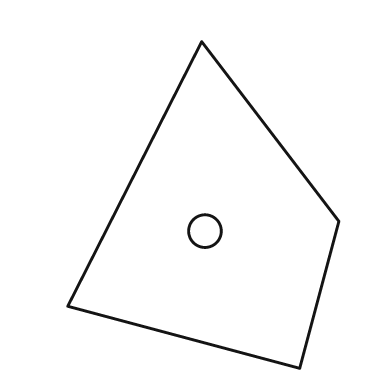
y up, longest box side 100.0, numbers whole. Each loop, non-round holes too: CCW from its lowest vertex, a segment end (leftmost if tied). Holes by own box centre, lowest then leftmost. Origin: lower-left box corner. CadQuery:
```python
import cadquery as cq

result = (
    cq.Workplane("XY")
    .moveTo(71.0, 0.0)
    .lineTo(83.0, 45.0)
    .lineTo(41.0, 100.0)
    .lineTo(0.0, 19.0)
    .close()
    .moveTo(42.0, 42.0)
    .circle(5.0)
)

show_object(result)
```